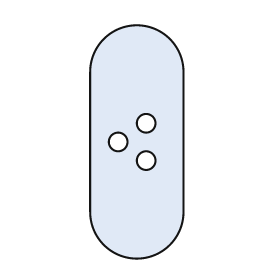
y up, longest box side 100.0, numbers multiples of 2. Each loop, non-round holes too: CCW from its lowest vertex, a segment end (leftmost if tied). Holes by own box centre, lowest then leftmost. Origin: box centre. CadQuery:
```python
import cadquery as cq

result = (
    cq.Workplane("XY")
    .moveTo(-20.0, -30.0)
    .threePointArc((0.0, -50.0), (20.0, -30.0))
    .lineTo(20.0, 30.0)
    .threePointArc((0.0, 50.0), (-20.0, 30.0))
    .close()
    .moveTo(4.0, -8.0)
    .circle(4.0)
    .moveTo(-8.0, 0.0)
    .circle(4.0)
    .moveTo(4.0, 8.0)
    .circle(4.0)
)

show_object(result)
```